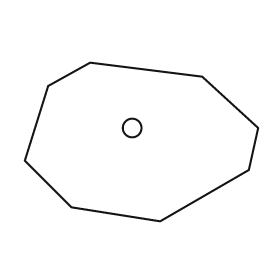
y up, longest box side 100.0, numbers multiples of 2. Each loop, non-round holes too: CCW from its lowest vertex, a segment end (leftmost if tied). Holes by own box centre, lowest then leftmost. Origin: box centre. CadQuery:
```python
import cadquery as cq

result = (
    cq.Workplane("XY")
    .moveTo(8.0, -34.0)
    .lineTo(46.0, -12.0)
    .lineTo(50.0, 6.0)
    .lineTo(26.0, 28.0)
    .lineTo(-22.0, 34.0)
    .lineTo(-40.0, 24.0)
    .lineTo(-50.0, -8.0)
    .lineTo(-30.0, -28.0)
    .close()
    .moveTo(-4.0, 6.0)
    .circle(4.0)
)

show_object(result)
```